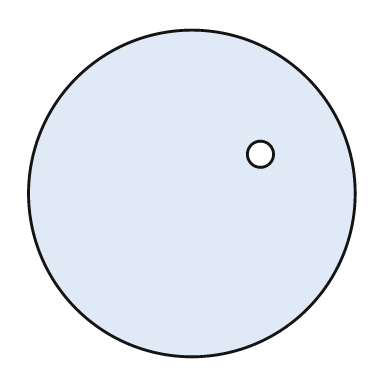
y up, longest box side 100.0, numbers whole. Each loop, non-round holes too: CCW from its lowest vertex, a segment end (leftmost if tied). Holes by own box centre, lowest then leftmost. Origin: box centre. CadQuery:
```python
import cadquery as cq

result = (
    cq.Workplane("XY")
    .moveTo(0.0, 0.0)
    .circle(50.0)
    .moveTo(21.0, 12.0)
    .circle(4.0)
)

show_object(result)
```